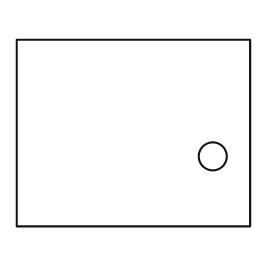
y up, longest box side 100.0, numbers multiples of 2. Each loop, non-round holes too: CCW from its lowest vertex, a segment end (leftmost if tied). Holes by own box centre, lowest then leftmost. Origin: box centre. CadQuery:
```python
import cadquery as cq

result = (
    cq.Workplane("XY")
    .moveTo(-50.0, -40.0)
    .lineTo(50.0, -40.0)
    .lineTo(50.0, 40.0)
    .lineTo(-50.0, 40.0)
    .close()
    .moveTo(34.0, -10.0)
    .circle(6.0)
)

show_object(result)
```